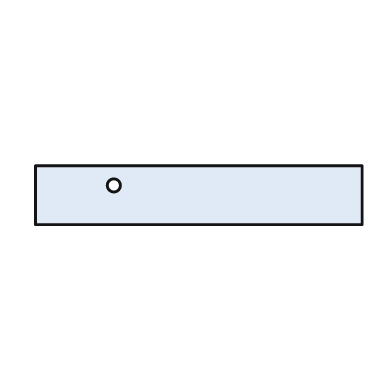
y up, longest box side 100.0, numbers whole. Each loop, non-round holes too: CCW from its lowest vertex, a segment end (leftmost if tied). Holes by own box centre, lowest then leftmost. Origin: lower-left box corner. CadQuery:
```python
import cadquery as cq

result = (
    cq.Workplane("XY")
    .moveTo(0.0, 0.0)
    .lineTo(100.0, 0.0)
    .lineTo(100.0, 18.0)
    .lineTo(0.0, 18.0)
    .close()
    .moveTo(24.0, 12.0)
    .circle(2.0)
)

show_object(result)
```